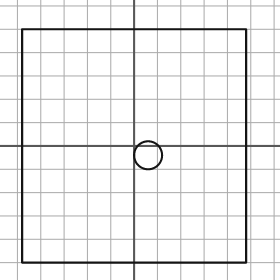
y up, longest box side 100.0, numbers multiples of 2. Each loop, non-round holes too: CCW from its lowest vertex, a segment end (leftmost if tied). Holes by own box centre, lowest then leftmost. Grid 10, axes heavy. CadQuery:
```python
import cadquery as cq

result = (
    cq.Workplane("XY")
    .moveTo(-48.0, -50.0)
    .lineTo(48.0, -50.0)
    .lineTo(48.0, 50.0)
    .lineTo(-48.0, 50.0)
    .close()
    .moveTo(6.0, -4.0)
    .circle(6.0)
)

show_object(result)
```